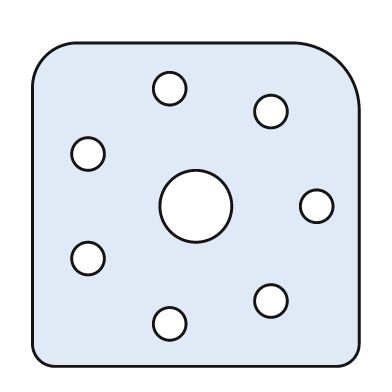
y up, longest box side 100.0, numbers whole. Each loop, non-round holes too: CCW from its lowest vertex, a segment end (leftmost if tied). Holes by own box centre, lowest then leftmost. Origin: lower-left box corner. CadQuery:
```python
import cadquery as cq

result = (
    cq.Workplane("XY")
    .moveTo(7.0, 0.0)
    .lineTo(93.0, 0.0)
    .threePointArc((98.0, 2.0), (100.0, 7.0))
    .lineTo(100.0, 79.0)
    .threePointArc((94.0, 93.0), (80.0, 99.0))
    .lineTo(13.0, 99.0)
    .threePointArc((4.0, 95.0), (0.0, 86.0))
    .lineTo(0.0, 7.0)
    .threePointArc((2.0, 2.0), (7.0, 0.0))
    .close()
    .moveTo(42.0, 13.0)
    .circle(5.0)
    .moveTo(73.0, 20.0)
    .circle(5.0)
    .moveTo(17.0, 33.0)
    .circle(5.0)
    .moveTo(50.0, 49.0)
    .circle(11.0)
    .moveTo(87.0, 49.0)
    .circle(5.0)
    .moveTo(17.0, 65.0)
    .circle(5.0)
    .moveTo(73.0, 78.0)
    .circle(5.0)
    .moveTo(42.0, 85.0)
    .circle(5.0)
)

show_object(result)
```